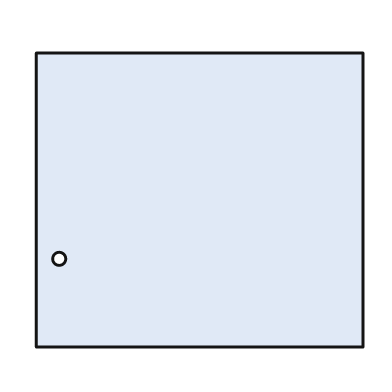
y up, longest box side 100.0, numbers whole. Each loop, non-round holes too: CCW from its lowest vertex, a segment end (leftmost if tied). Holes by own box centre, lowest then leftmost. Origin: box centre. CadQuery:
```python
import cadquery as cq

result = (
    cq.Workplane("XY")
    .moveTo(-50.0, -45.0)
    .lineTo(50.0, -45.0)
    .lineTo(50.0, 45.0)
    .lineTo(-50.0, 45.0)
    .close()
    .moveTo(-43.0, -18.0)
    .circle(2.0)
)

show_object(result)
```